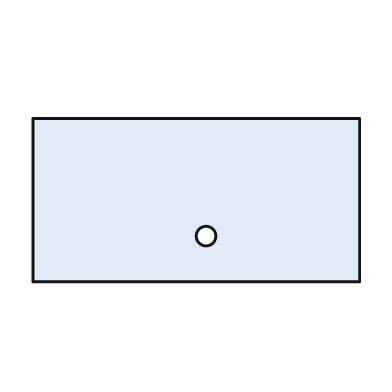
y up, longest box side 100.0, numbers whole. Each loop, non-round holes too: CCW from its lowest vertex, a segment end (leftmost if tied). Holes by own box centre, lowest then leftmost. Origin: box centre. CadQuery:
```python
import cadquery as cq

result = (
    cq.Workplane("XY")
    .moveTo(-50.0, -25.0)
    .lineTo(50.0, -25.0)
    .lineTo(50.0, 25.0)
    .lineTo(-50.0, 25.0)
    .close()
    .moveTo(3.0, -11.0)
    .circle(3.0)
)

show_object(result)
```